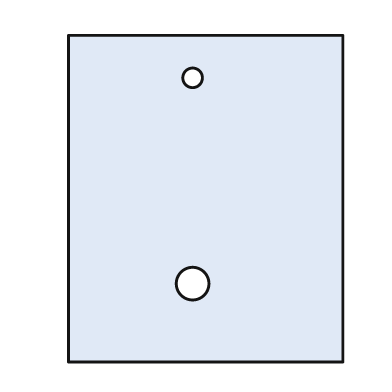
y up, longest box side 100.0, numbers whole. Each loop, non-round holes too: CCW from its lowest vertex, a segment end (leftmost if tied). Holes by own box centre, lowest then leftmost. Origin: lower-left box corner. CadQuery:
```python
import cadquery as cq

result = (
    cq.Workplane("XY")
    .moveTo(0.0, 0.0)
    .lineTo(84.0, 0.0)
    .lineTo(84.0, 100.0)
    .lineTo(0.0, 100.0)
    .close()
    .moveTo(38.0, 24.0)
    .circle(5.0)
    .moveTo(38.0, 87.0)
    .circle(3.0)
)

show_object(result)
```